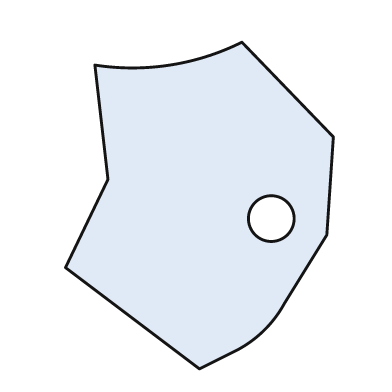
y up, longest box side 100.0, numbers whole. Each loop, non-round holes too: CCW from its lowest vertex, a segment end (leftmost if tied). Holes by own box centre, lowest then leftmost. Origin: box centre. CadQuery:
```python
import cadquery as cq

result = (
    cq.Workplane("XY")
    .moveTo(0.0, -50.0)
    .lineTo(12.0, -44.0)
    .threePointArc((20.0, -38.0), (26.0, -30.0))
    .lineTo(39.0, -9.0)
    .lineTo(41.0, 21.0)
    .lineTo(13.0, 50.0)
    .threePointArc((-9.0, 43.0), (-32.0, 43.0))
    .lineTo(-28.0, 8.0)
    .lineTo(-41.0, -19.0)
    .close()
    .moveTo(22.0, -4.0)
    .circle(7.0)
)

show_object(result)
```